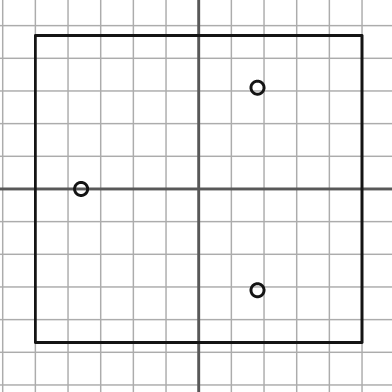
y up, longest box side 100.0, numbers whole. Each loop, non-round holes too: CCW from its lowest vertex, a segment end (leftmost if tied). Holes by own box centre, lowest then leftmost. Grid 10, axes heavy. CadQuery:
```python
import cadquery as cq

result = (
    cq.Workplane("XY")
    .moveTo(-50.0, -47.0)
    .lineTo(50.0, -47.0)
    .lineTo(50.0, 47.0)
    .lineTo(-50.0, 47.0)
    .close()
    .moveTo(18.0, -31.0)
    .circle(2.0)
    .moveTo(-36.0, 0.0)
    .circle(2.0)
    .moveTo(18.0, 31.0)
    .circle(2.0)
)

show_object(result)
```